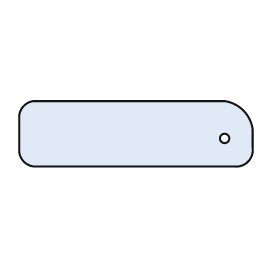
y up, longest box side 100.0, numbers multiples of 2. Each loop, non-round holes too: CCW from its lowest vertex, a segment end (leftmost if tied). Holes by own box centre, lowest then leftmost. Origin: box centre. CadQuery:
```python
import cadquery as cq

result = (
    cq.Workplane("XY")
    .moveTo(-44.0, -14.0)
    .lineTo(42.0, -14.0)
    .threePointArc((48.0, -12.0), (50.0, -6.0))
    .lineTo(50.0, 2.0)
    .threePointArc((46.0, 10.0), (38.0, 14.0))
    .lineTo(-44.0, 14.0)
    .threePointArc((-48.0, 12.0), (-50.0, 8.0))
    .lineTo(-50.0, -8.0)
    .threePointArc((-48.0, -12.0), (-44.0, -14.0))
    .close()
    .moveTo(38.0, -2.0)
    .circle(2.0)
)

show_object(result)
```